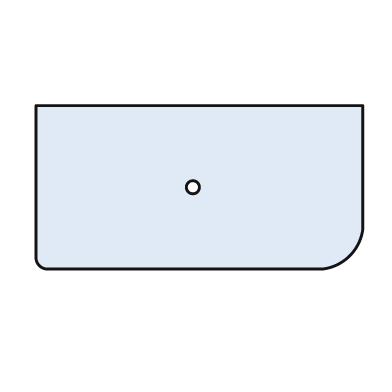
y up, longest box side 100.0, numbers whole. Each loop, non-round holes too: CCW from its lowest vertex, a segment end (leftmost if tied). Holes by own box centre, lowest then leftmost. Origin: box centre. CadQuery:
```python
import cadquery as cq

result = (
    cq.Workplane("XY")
    .moveTo(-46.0, -25.0)
    .lineTo(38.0, -25.0)
    .threePointArc((46.0, -21.0), (50.0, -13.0))
    .lineTo(50.0, 25.0)
    .lineTo(-50.0, 25.0)
    .lineTo(-50.0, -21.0)
    .threePointArc((-49.0, -24.0), (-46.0, -25.0))
    .close()
    .moveTo(-2.0, 0.0)
    .circle(2.0)
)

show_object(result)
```